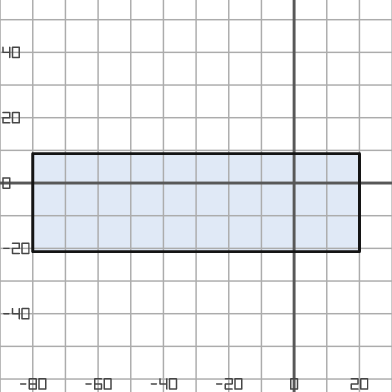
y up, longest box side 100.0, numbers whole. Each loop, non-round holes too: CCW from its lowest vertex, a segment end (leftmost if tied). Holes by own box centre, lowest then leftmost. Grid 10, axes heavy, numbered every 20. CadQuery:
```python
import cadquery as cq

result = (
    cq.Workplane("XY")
    .moveTo(-80.0, -21.0)
    .lineTo(20.0, -21.0)
    .lineTo(20.0, 9.0)
    .lineTo(-80.0, 9.0)
    .close()
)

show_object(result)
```